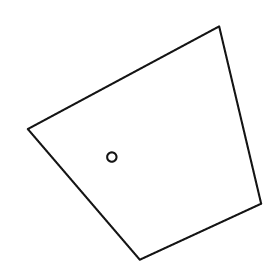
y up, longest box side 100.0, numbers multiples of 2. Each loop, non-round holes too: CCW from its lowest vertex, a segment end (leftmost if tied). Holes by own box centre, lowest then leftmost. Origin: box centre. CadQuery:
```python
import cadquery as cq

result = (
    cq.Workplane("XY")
    .moveTo(-2.0, -50.0)
    .lineTo(50.0, -26.0)
    .lineTo(32.0, 50.0)
    .lineTo(-50.0, 6.0)
    .close()
    .moveTo(-14.0, -6.0)
    .circle(2.0)
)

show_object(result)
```